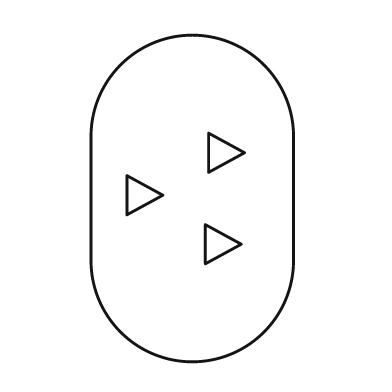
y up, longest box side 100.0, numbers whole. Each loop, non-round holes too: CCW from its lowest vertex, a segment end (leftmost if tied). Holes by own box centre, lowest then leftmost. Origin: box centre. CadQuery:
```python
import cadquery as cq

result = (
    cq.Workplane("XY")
    .moveTo(-31.0, -19.0)
    .threePointArc((0.0, -50.0), (31.0, -19.0))
    .lineTo(31.0, 19.0)
    .threePointArc((0.0, 50.0), (-31.0, 19.0))
    .close()
    .moveTo(4.0, -20.0)
    .lineTo(15.0, -14.0)
    .lineTo(4.0, -8.0)
    .close()
    .moveTo(-20.0, -5.0)
    .lineTo(-9.0, 1.0)
    .lineTo(-20.0, 7.0)
    .close()
    .moveTo(5.0, 8.0)
    .lineTo(16.0, 14.0)
    .lineTo(5.0, 20.0)
    .close()
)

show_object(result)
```